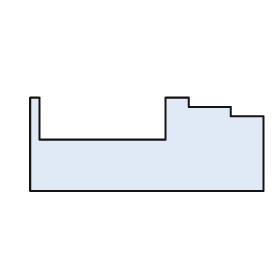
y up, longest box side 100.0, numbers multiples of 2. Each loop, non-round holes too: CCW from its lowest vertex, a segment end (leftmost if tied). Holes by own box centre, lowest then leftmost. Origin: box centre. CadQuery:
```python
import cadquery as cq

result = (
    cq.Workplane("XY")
    .moveTo(-50.0, -20.0)
    .lineTo(50.0, -20.0)
    .lineTo(50.0, 12.0)
    .lineTo(36.0, 12.0)
    .lineTo(36.0, 16.0)
    .lineTo(18.0, 16.0)
    .lineTo(18.0, 20.0)
    .lineTo(8.0, 20.0)
    .lineTo(8.0, 2.0)
    .lineTo(-46.0, 2.0)
    .lineTo(-46.0, 20.0)
    .lineTo(-50.0, 20.0)
    .close()
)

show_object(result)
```